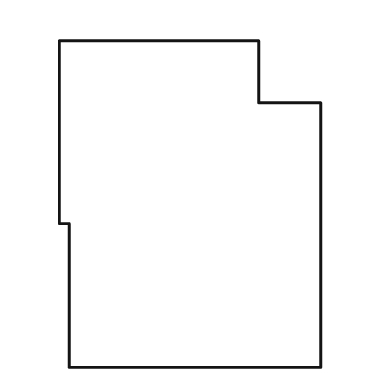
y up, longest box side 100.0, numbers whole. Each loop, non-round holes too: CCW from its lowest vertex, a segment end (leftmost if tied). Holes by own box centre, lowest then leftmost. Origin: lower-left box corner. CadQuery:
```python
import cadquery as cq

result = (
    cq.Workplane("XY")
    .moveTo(3.0, 0.0)
    .lineTo(80.0, 0.0)
    .lineTo(80.0, 81.0)
    .lineTo(61.0, 81.0)
    .lineTo(61.0, 100.0)
    .lineTo(0.0, 100.0)
    .lineTo(0.0, 44.0)
    .lineTo(3.0, 44.0)
    .close()
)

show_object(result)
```